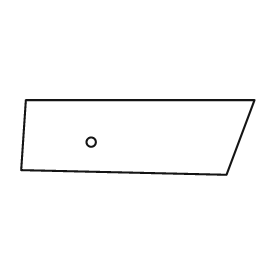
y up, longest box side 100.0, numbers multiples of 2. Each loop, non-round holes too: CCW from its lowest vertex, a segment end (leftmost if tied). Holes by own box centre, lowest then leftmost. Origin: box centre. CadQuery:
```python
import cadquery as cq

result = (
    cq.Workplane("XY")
    .moveTo(38.0, -16.0)
    .lineTo(50.0, 16.0)
    .lineTo(-48.0, 16.0)
    .lineTo(-50.0, -14.0)
    .close()
    .moveTo(-20.0, -2.0)
    .circle(2.0)
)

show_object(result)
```